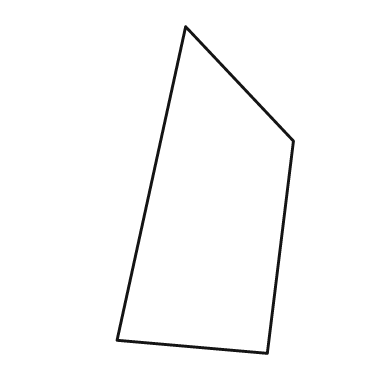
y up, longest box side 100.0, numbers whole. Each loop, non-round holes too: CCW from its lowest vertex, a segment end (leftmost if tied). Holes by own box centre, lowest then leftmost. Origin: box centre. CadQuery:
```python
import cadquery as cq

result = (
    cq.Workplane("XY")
    .moveTo(19.0, -50.0)
    .lineTo(27.0, 15.0)
    .lineTo(-6.0, 50.0)
    .lineTo(-27.0, -46.0)
    .close()
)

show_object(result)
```